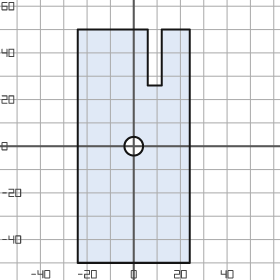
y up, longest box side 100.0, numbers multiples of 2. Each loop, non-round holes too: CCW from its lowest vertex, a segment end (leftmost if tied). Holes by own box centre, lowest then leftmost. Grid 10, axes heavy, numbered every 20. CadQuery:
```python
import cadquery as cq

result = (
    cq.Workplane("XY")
    .moveTo(-24.0, -50.0)
    .lineTo(24.0, -50.0)
    .lineTo(24.0, 50.0)
    .lineTo(12.0, 50.0)
    .lineTo(12.0, 26.0)
    .lineTo(6.0, 26.0)
    .lineTo(6.0, 50.0)
    .lineTo(-24.0, 50.0)
    .close()
    .moveTo(0.0, 0.0)
    .circle(4.0)
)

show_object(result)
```